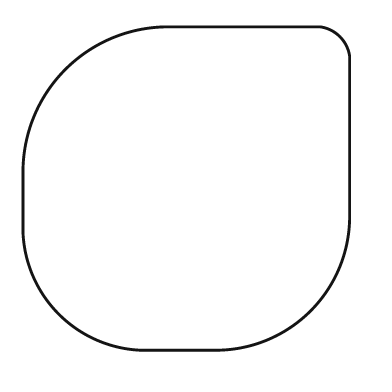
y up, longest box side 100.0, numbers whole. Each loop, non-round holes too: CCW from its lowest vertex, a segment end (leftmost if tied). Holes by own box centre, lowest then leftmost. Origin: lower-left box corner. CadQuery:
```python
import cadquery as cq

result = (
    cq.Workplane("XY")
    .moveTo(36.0, 0.0)
    .lineTo(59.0, 0.0)
    .threePointArc((88.0, 12.0), (100.0, 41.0))
    .lineTo(100.0, 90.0)
    .threePointArc((97.0, 96.0), (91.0, 99.0))
    .lineTo(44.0, 99.0)
    .threePointArc((13.0, 86.0), (0.0, 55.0))
    .lineTo(0.0, 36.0)
    .threePointArc((11.0, 11.0), (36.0, 0.0))
    .close()
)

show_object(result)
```